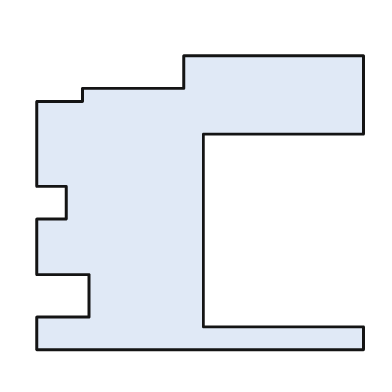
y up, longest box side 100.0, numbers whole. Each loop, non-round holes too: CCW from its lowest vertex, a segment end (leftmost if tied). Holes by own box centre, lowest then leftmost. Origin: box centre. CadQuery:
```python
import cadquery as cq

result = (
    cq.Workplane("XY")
    .moveTo(-50.0, -45.0)
    .lineTo(50.0, -45.0)
    .lineTo(50.0, -38.0)
    .lineTo(1.0, -38.0)
    .lineTo(1.0, 21.0)
    .lineTo(50.0, 21.0)
    .lineTo(50.0, 45.0)
    .lineTo(-5.0, 45.0)
    .lineTo(-5.0, 35.0)
    .lineTo(-36.0, 35.0)
    .lineTo(-36.0, 31.0)
    .lineTo(-50.0, 31.0)
    .lineTo(-50.0, 5.0)
    .lineTo(-41.0, 5.0)
    .lineTo(-41.0, -5.0)
    .lineTo(-50.0, -5.0)
    .lineTo(-50.0, -22.0)
    .lineTo(-34.0, -22.0)
    .lineTo(-34.0, -35.0)
    .lineTo(-50.0, -35.0)
    .close()
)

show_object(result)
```